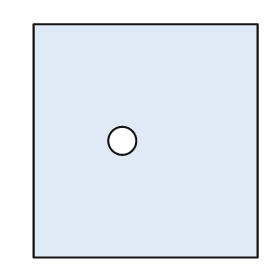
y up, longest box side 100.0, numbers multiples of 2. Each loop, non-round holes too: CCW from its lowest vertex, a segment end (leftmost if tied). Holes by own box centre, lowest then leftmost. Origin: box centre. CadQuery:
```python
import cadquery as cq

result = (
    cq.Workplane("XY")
    .moveTo(-48.0, -50.0)
    .lineTo(48.0, -50.0)
    .lineTo(48.0, 50.0)
    .lineTo(-48.0, 50.0)
    .close()
    .moveTo(-10.0, 0.0)
    .circle(6.0)
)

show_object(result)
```